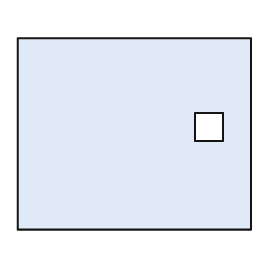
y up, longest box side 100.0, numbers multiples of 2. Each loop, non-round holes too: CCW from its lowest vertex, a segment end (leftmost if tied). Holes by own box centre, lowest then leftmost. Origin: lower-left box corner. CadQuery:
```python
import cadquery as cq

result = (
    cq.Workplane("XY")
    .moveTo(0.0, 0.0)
    .lineTo(100.0, 0.0)
    .lineTo(100.0, 82.0)
    .lineTo(0.0, 82.0)
    .close()
    .moveTo(76.0, 38.0)
    .lineTo(88.0, 38.0)
    .lineTo(88.0, 50.0)
    .lineTo(76.0, 50.0)
    .close()
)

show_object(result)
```